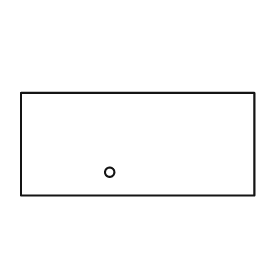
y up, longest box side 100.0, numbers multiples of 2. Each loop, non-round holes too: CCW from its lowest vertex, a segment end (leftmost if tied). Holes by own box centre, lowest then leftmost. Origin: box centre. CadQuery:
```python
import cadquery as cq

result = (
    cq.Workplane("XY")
    .moveTo(-50.0, -22.0)
    .lineTo(50.0, -22.0)
    .lineTo(50.0, 22.0)
    .lineTo(-50.0, 22.0)
    .close()
    .moveTo(-12.0, -12.0)
    .circle(2.0)
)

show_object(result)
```